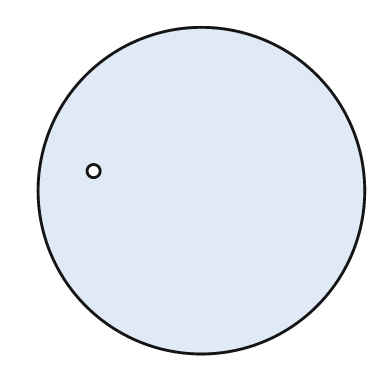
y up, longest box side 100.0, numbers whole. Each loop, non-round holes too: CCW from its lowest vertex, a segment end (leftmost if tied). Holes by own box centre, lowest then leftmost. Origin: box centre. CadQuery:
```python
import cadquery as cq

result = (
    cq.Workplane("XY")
    .moveTo(0.0, 0.0)
    .circle(50.0)
    .moveTo(-33.0, 6.0)
    .circle(2.0)
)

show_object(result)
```